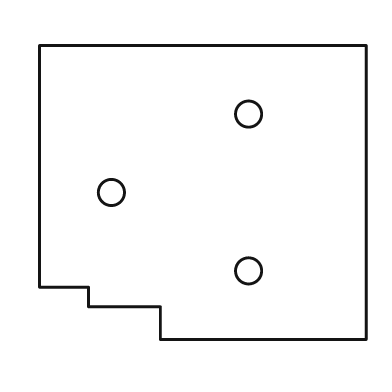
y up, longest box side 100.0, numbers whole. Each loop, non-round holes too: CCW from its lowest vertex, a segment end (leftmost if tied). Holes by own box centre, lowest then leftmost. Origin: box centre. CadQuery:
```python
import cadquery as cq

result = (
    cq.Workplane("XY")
    .moveTo(-13.0, -45.0)
    .lineTo(50.0, -45.0)
    .lineTo(50.0, 45.0)
    .lineTo(-50.0, 45.0)
    .lineTo(-50.0, -29.0)
    .lineTo(-35.0, -29.0)
    .lineTo(-35.0, -35.0)
    .lineTo(-13.0, -35.0)
    .close()
    .moveTo(14.0, -24.0)
    .circle(4.0)
    .moveTo(-28.0, 0.0)
    .circle(4.0)
    .moveTo(14.0, 24.0)
    .circle(4.0)
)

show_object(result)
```